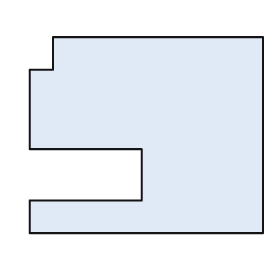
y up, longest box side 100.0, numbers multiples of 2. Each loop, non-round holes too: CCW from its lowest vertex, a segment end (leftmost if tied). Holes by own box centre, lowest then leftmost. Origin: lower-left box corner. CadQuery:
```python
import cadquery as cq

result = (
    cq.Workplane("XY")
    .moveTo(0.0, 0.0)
    .lineTo(100.0, 0.0)
    .lineTo(100.0, 84.0)
    .lineTo(10.0, 84.0)
    .lineTo(10.0, 70.0)
    .lineTo(0.0, 70.0)
    .lineTo(0.0, 36.0)
    .lineTo(48.0, 36.0)
    .lineTo(48.0, 14.0)
    .lineTo(0.0, 14.0)
    .close()
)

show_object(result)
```